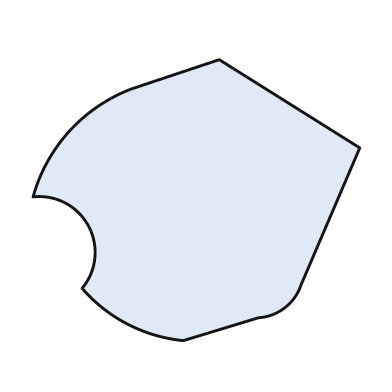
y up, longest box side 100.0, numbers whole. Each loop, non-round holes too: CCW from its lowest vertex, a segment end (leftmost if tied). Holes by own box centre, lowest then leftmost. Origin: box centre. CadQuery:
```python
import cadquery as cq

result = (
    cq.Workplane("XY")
    .moveTo(-4.0, -43.0)
    .lineTo(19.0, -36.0)
    .threePointArc((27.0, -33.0), (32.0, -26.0))
    .lineTo(50.0, 16.0)
    .lineTo(7.0, 43.0)
    .lineTo(-20.0, 34.0)
    .threePointArc((-39.0, 21.0), (-50.0, 1.0))
    .threePointArc((-33.0, -8.0), (-35.0, -27.0))
    .threePointArc((-21.0, -38.0), (-4.0, -43.0))
    .close()
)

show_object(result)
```